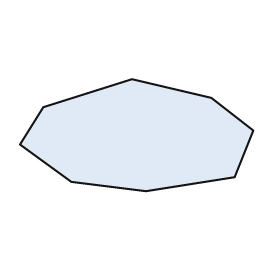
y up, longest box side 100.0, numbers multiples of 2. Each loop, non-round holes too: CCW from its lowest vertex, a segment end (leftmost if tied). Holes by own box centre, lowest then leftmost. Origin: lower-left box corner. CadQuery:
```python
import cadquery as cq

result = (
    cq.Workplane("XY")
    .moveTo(54.0, 0.0)
    .lineTo(92.0, 6.0)
    .lineTo(100.0, 26.0)
    .lineTo(82.0, 40.0)
    .lineTo(48.0, 48.0)
    .lineTo(10.0, 36.0)
    .lineTo(0.0, 20.0)
    .lineTo(22.0, 4.0)
    .close()
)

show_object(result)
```